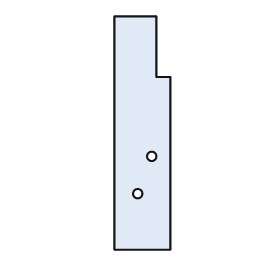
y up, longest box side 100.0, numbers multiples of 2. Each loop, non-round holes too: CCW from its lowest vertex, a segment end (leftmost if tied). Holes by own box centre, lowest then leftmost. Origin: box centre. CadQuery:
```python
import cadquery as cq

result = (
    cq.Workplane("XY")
    .moveTo(-12.0, -50.0)
    .lineTo(12.0, -50.0)
    .lineTo(12.0, 24.0)
    .lineTo(6.0, 24.0)
    .lineTo(6.0, 50.0)
    .lineTo(-12.0, 50.0)
    .close()
    .moveTo(-2.0, -26.0)
    .circle(2.0)
    .moveTo(4.0, -10.0)
    .circle(2.0)
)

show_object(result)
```